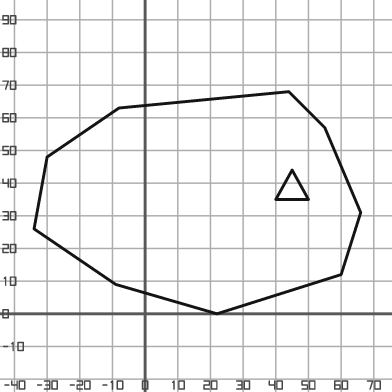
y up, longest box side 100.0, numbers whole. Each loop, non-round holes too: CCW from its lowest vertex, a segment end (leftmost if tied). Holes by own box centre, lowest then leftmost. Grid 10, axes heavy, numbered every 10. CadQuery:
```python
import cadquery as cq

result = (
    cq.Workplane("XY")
    .moveTo(22.0, 0.0)
    .lineTo(60.0, 12.0)
    .lineTo(66.0, 31.0)
    .lineTo(55.0, 57.0)
    .lineTo(44.0, 68.0)
    .lineTo(-8.0, 63.0)
    .lineTo(-30.0, 48.0)
    .lineTo(-34.0, 26.0)
    .lineTo(-9.0, 9.0)
    .close()
    .moveTo(40.0, 35.0)
    .lineTo(50.0, 35.0)
    .lineTo(45.0, 44.0)
    .close()
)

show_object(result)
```